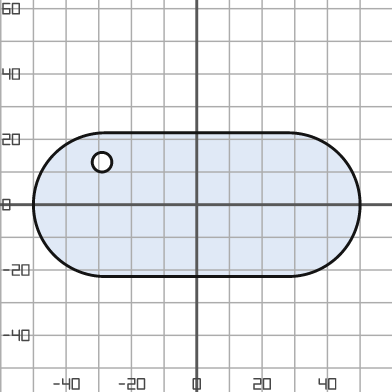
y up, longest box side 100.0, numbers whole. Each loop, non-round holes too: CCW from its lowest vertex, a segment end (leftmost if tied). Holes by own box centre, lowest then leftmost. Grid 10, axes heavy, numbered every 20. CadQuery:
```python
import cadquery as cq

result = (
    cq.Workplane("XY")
    .moveTo(-28.0, -22.0)
    .lineTo(28.0, -22.0)
    .threePointArc((50.0, 0.0), (28.0, 22.0))
    .lineTo(-28.0, 22.0)
    .threePointArc((-50.0, 0.0), (-28.0, -22.0))
    .close()
    .moveTo(-29.0, 13.0)
    .circle(3.0)
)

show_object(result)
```